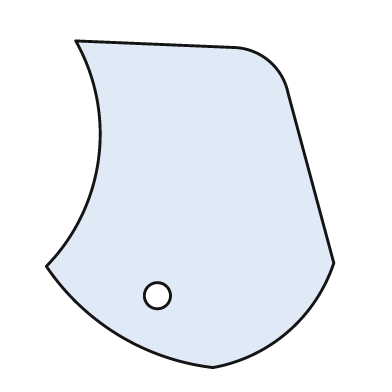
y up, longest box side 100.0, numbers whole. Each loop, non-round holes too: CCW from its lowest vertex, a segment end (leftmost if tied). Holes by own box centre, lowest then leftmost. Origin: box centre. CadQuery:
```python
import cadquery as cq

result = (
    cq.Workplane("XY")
    .moveTo(7.0, -50.0)
    .threePointArc((30.0, -39.0), (44.0, -18.0))
    .lineTo(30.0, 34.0)
    .threePointArc((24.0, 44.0), (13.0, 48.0))
    .lineTo(-35.0, 50.0)
    .threePointArc((-28.0, 14.0), (-44.0, -19.0))
    .threePointArc((-22.0, -40.0), (7.0, -50.0))
    .close()
    .moveTo(-10.0, -28.0)
    .circle(4.0)
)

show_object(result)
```